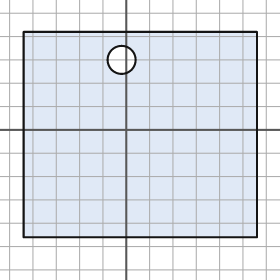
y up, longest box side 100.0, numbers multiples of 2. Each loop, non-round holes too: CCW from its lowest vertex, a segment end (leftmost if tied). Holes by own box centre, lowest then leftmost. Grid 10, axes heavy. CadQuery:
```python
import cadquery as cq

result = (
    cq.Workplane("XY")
    .moveTo(-44.0, -46.0)
    .lineTo(56.0, -46.0)
    .lineTo(56.0, 42.0)
    .lineTo(-44.0, 42.0)
    .close()
    .moveTo(-2.0, 30.0)
    .circle(6.0)
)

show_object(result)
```